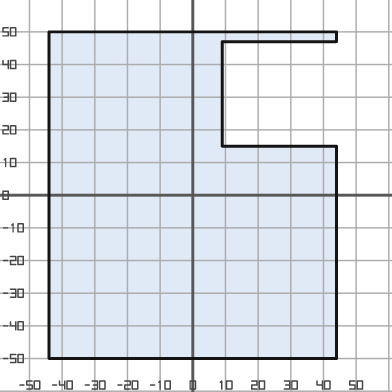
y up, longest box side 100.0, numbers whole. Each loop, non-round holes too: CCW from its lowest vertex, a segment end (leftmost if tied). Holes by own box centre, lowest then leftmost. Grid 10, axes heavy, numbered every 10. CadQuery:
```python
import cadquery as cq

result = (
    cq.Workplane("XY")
    .moveTo(-44.0, -50.0)
    .lineTo(44.0, -50.0)
    .lineTo(44.0, 15.0)
    .lineTo(9.0, 15.0)
    .lineTo(9.0, 47.0)
    .lineTo(44.0, 47.0)
    .lineTo(44.0, 50.0)
    .lineTo(-44.0, 50.0)
    .close()
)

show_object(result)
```